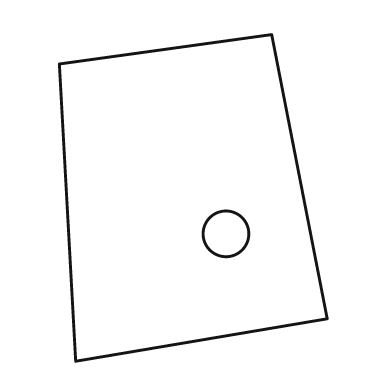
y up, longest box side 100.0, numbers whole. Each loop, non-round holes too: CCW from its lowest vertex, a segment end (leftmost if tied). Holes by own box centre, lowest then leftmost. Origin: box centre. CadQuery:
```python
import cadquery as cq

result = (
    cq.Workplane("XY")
    .moveTo(-36.0, -50.0)
    .lineTo(41.0, -37.0)
    .lineTo(24.0, 50.0)
    .lineTo(-41.0, 41.0)
    .close()
    .moveTo(10.0, -11.0)
    .circle(7.0)
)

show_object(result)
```